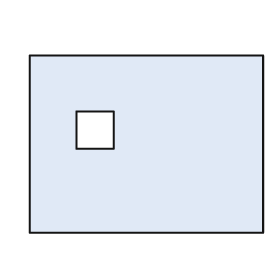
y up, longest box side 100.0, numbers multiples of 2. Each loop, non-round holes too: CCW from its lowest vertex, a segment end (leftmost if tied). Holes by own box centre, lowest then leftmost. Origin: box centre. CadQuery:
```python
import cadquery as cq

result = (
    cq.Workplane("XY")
    .moveTo(-50.0, -38.0)
    .lineTo(50.0, -38.0)
    .lineTo(50.0, 38.0)
    .lineTo(-50.0, 38.0)
    .close()
    .moveTo(-30.0, -2.0)
    .lineTo(-14.0, -2.0)
    .lineTo(-14.0, 14.0)
    .lineTo(-30.0, 14.0)
    .close()
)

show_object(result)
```